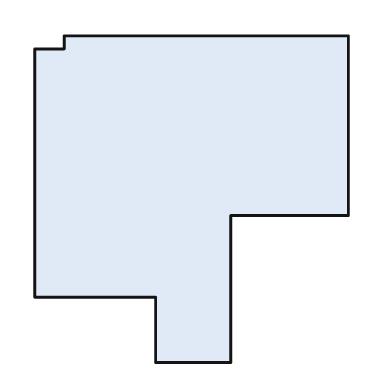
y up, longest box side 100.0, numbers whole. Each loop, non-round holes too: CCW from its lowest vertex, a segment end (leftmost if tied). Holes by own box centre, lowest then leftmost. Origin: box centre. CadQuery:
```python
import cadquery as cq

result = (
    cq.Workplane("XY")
    .moveTo(-11.0, -50.0)
    .lineTo(12.0, -50.0)
    .lineTo(12.0, -5.0)
    .lineTo(48.0, -5.0)
    .lineTo(48.0, 50.0)
    .lineTo(-39.0, 50.0)
    .lineTo(-39.0, 46.0)
    .lineTo(-48.0, 46.0)
    .lineTo(-48.0, -30.0)
    .lineTo(-11.0, -30.0)
    .close()
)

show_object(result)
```